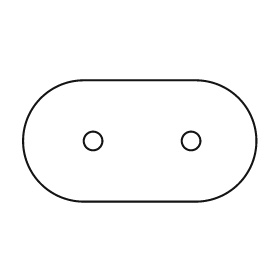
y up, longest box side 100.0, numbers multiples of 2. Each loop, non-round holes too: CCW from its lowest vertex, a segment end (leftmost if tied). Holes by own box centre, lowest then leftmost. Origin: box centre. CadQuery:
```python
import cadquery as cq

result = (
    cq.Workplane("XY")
    .moveTo(-24.0, -26.0)
    .lineTo(24.0, -26.0)
    .threePointArc((50.0, 0.0), (24.0, 26.0))
    .lineTo(-24.0, 26.0)
    .threePointArc((-50.0, 0.0), (-24.0, -26.0))
    .close()
    .moveTo(-20.0, 0.0)
    .circle(4.0)
    .moveTo(22.0, 0.0)
    .circle(4.0)
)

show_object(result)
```